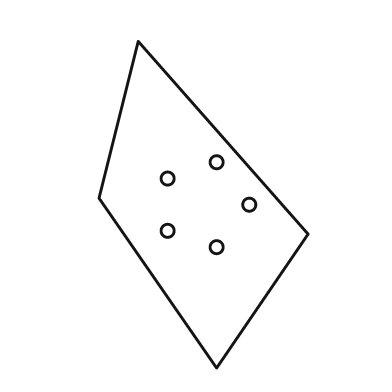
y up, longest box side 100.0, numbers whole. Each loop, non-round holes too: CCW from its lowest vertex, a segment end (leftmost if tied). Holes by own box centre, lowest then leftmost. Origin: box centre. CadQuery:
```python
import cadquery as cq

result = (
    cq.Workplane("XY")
    .moveTo(4.0, -50.0)
    .lineTo(32.0, -9.0)
    .lineTo(-20.0, 50.0)
    .lineTo(-32.0, 2.0)
    .close()
    .moveTo(4.0, -13.0)
    .circle(2.0)
    .moveTo(-11.0, -8.0)
    .circle(2.0)
    .moveTo(14.0, 0.0)
    .circle(2.0)
    .moveTo(-11.0, 8.0)
    .circle(2.0)
    .moveTo(4.0, 13.0)
    .circle(2.0)
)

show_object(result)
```